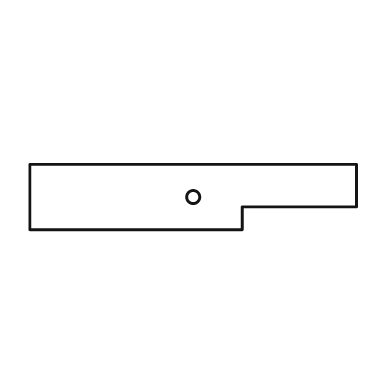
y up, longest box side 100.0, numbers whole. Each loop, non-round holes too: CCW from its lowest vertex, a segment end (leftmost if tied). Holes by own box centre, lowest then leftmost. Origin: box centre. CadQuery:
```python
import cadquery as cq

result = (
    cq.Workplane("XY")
    .moveTo(-50.0, -10.0)
    .lineTo(15.0, -10.0)
    .lineTo(15.0, -3.0)
    .lineTo(50.0, -3.0)
    .lineTo(50.0, 10.0)
    .lineTo(-50.0, 10.0)
    .close()
    .moveTo(0.0, 0.0)
    .circle(2.0)
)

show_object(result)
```